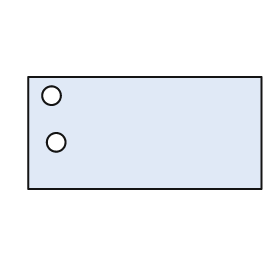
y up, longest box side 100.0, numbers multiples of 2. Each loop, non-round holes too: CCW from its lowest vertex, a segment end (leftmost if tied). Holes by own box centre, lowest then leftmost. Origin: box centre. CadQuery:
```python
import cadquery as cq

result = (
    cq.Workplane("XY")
    .moveTo(-50.0, -24.0)
    .lineTo(50.0, -24.0)
    .lineTo(50.0, 24.0)
    .lineTo(-50.0, 24.0)
    .close()
    .moveTo(-38.0, -4.0)
    .circle(4.0)
    .moveTo(-40.0, 16.0)
    .circle(4.0)
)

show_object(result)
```